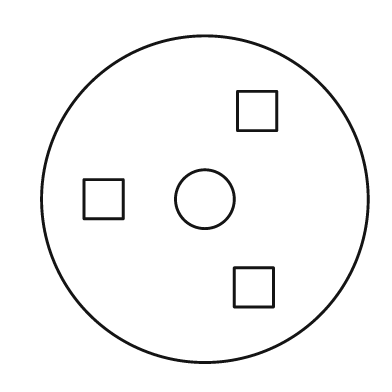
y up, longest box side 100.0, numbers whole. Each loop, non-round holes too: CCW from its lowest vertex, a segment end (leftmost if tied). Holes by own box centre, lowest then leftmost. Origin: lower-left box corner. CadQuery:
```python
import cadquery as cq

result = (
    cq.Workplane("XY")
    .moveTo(50.0, 50.0)
    .circle(50.0)
    .moveTo(59.0, 17.0)
    .lineTo(71.0, 17.0)
    .lineTo(71.0, 29.0)
    .lineTo(59.0, 29.0)
    .close()
    .moveTo(13.0, 44.0)
    .lineTo(25.0, 44.0)
    .lineTo(25.0, 56.0)
    .lineTo(13.0, 56.0)
    .close()
    .moveTo(50.0, 50.0)
    .circle(9.0)
    .moveTo(60.0, 71.0)
    .lineTo(72.0, 71.0)
    .lineTo(72.0, 83.0)
    .lineTo(60.0, 83.0)
    .close()
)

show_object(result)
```